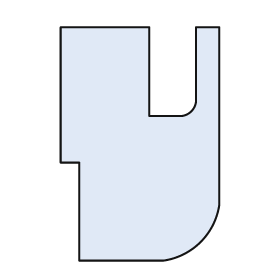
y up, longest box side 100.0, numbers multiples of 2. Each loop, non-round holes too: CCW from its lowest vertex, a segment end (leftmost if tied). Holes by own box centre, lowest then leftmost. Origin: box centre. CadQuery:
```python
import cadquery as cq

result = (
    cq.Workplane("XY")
    .moveTo(-26.0, -50.0)
    .lineTo(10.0, -50.0)
    .threePointArc((26.0, -42.0), (34.0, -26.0))
    .lineTo(34.0, 50.0)
    .lineTo(24.0, 50.0)
    .lineTo(24.0, 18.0)
    .threePointArc((22.0, 14.0), (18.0, 12.0))
    .lineTo(4.0, 12.0)
    .lineTo(4.0, 50.0)
    .lineTo(-34.0, 50.0)
    .lineTo(-34.0, -8.0)
    .lineTo(-26.0, -8.0)
    .close()
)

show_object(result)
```